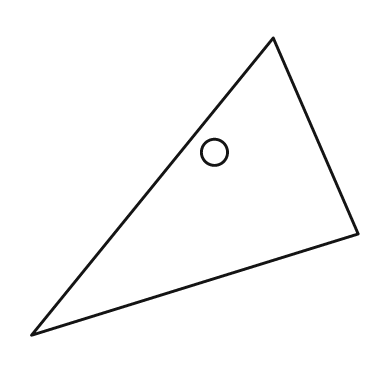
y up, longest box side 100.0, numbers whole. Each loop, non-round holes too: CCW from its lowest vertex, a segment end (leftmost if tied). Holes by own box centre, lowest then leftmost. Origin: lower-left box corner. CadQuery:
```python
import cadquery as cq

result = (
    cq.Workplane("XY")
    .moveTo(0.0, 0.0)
    .lineTo(100.0, 31.0)
    .lineTo(74.0, 91.0)
    .close()
    .moveTo(56.0, 56.0)
    .circle(4.0)
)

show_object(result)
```